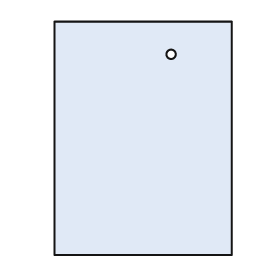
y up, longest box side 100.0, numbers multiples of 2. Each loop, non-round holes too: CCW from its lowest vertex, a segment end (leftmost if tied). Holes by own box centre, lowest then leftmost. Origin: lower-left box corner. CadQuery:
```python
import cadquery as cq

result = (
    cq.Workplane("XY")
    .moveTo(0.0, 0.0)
    .lineTo(76.0, 0.0)
    .lineTo(76.0, 100.0)
    .lineTo(0.0, 100.0)
    .close()
    .moveTo(50.0, 86.0)
    .circle(2.0)
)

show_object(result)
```